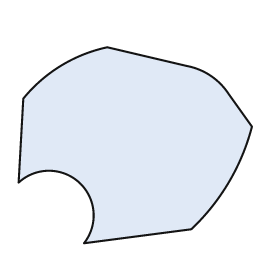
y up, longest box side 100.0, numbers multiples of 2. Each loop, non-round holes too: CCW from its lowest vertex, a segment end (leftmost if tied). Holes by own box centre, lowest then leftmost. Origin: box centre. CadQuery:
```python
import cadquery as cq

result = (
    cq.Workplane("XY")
    .moveTo(-22.0, -42.0)
    .lineTo(24.0, -36.0)
    .threePointArc((40.0, -16.0), (50.0, 8.0))
    .lineTo(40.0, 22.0)
    .threePointArc((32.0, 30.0), (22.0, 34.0))
    .lineTo(-12.0, 42.0)
    .threePointArc((-32.0, 34.0), (-48.0, 20.0))
    .lineTo(-50.0, -16.0)
    .threePointArc((-24.0, -16.0), (-22.0, -42.0))
    .close()
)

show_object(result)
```